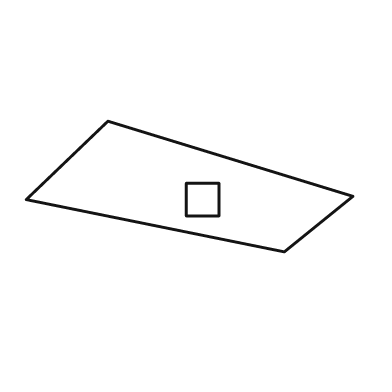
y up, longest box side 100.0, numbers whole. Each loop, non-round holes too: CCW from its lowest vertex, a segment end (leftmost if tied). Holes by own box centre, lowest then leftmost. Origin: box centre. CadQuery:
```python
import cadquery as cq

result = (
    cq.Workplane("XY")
    .moveTo(29.0, -20.0)
    .lineTo(50.0, -3.0)
    .lineTo(-25.0, 20.0)
    .lineTo(-50.0, -4.0)
    .close()
    .moveTo(-1.0, -9.0)
    .lineTo(9.0, -9.0)
    .lineTo(9.0, 1.0)
    .lineTo(-1.0, 1.0)
    .close()
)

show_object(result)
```